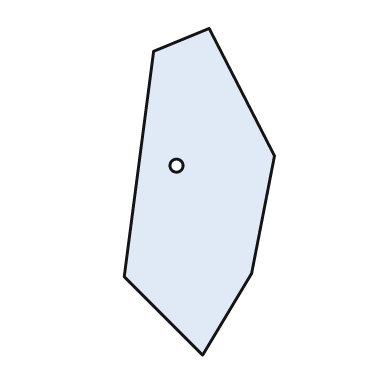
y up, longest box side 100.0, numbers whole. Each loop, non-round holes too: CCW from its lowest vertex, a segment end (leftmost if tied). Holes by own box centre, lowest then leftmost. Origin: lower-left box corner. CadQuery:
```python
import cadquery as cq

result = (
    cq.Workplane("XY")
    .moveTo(24.0, 0.0)
    .lineTo(39.0, 25.0)
    .lineTo(46.0, 61.0)
    .lineTo(26.0, 100.0)
    .lineTo(9.0, 93.0)
    .lineTo(0.0, 24.0)
    .close()
    .moveTo(16.0, 58.0)
    .circle(2.0)
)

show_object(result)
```